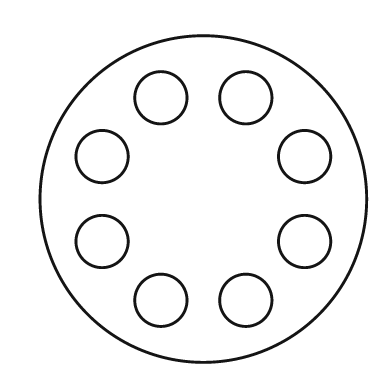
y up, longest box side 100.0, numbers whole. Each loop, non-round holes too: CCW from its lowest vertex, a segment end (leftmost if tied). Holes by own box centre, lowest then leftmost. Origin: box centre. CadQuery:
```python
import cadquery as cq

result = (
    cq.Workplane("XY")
    .moveTo(0.0, 0.0)
    .circle(50.0)
    .moveTo(-13.0, -31.0)
    .circle(8.0)
    .moveTo(13.0, -31.0)
    .circle(8.0)
    .moveTo(-31.0, -13.0)
    .circle(8.0)
    .moveTo(31.0, -13.0)
    .circle(8.0)
    .moveTo(-31.0, 13.0)
    .circle(8.0)
    .moveTo(31.0, 13.0)
    .circle(8.0)
    .moveTo(-13.0, 31.0)
    .circle(8.0)
    .moveTo(13.0, 31.0)
    .circle(8.0)
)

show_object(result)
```